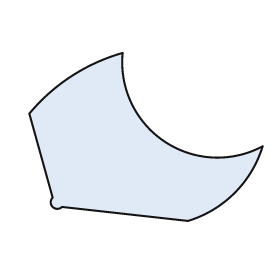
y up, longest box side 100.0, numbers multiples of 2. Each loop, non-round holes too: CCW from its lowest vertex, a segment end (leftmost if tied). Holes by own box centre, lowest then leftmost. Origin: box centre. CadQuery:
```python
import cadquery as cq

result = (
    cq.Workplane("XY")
    .moveTo(18.0, -36.0)
    .threePointArc((38.0, -24.0), (50.0, -4.0))
    .threePointArc((8.0, -2.0), (-10.0, 36.0))
    .threePointArc((-32.0, 26.0), (-50.0, 10.0))
    .lineTo(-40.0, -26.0)
    .threePointArc((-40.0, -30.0), (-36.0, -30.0))
    .close()
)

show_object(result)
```